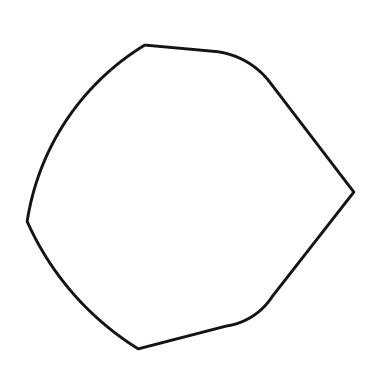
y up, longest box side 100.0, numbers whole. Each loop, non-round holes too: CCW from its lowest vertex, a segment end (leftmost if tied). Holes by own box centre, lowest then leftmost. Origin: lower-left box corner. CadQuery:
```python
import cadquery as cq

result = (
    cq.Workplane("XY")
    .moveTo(34.0, 0.0)
    .lineTo(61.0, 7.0)
    .threePointArc((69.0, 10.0), (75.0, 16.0))
    .lineTo(100.0, 48.0)
    .lineTo(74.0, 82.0)
    .threePointArc((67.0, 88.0), (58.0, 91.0))
    .lineTo(36.0, 93.0)
    .threePointArc((12.0, 70.0), (0.0, 39.0))
    .threePointArc((14.0, 17.0), (34.0, 0.0))
    .close()
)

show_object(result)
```